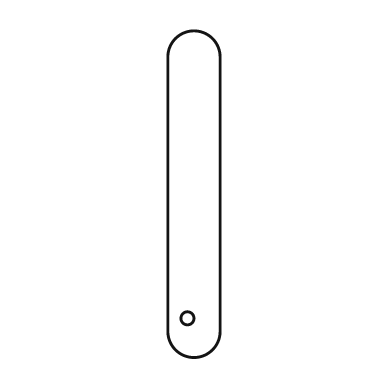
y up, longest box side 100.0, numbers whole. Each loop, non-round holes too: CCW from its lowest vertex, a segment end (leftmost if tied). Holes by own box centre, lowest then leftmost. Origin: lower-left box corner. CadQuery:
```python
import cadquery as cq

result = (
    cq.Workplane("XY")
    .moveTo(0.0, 8.0)
    .threePointArc((8.0, 0.0), (16.0, 8.0))
    .lineTo(16.0, 92.0)
    .threePointArc((8.0, 100.0), (0.0, 92.0))
    .close()
    .moveTo(6.0, 12.0)
    .circle(2.0)
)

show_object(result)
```